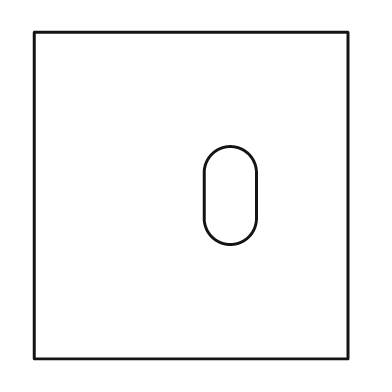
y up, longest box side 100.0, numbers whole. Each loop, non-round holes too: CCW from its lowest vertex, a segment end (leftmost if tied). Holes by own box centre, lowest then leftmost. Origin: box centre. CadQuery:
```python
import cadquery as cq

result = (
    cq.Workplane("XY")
    .moveTo(-48.0, -50.0)
    .lineTo(48.0, -50.0)
    .lineTo(48.0, 50.0)
    .lineTo(-48.0, 50.0)
    .close()
    .moveTo(4.0, -7.0)
    .threePointArc((12.0, -15.0), (20.0, -7.0))
    .lineTo(20.0, 7.0)
    .threePointArc((12.0, 15.0), (4.0, 7.0))
    .close()
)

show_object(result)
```